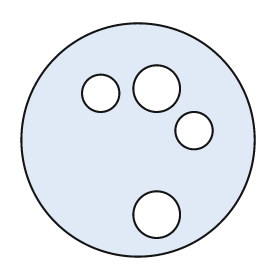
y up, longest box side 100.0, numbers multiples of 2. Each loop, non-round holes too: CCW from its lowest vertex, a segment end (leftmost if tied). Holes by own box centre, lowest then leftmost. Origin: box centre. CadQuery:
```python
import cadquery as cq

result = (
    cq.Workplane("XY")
    .moveTo(0.0, 0.0)
    .circle(50.0)
    .moveTo(8.0, -32.0)
    .circle(10.0)
    .moveTo(24.0, 4.0)
    .circle(8.0)
    .moveTo(-16.0, 20.0)
    .circle(8.0)
    .moveTo(8.0, 22.0)
    .circle(10.0)
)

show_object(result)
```